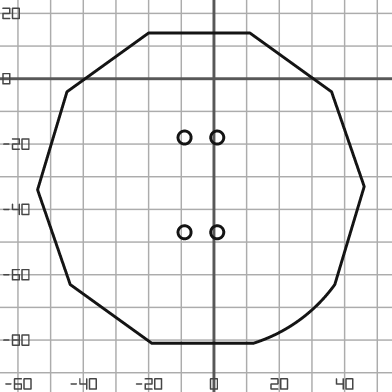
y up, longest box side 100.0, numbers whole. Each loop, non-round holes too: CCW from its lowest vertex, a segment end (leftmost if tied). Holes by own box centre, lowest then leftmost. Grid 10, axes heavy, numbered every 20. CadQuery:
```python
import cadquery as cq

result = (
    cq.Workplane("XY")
    .moveTo(-19.0, -81.0)
    .lineTo(12.0, -81.0)
    .threePointArc((26.0, -74.0), (37.0, -63.0))
    .lineTo(46.0, -33.0)
    .lineTo(36.0, -4.0)
    .lineTo(11.0, 14.0)
    .lineTo(-20.0, 14.0)
    .lineTo(-45.0, -4.0)
    .lineTo(-54.0, -34.0)
    .lineTo(-44.0, -63.0)
    .close()
    .moveTo(-9.0, -47.0)
    .circle(2.0)
    .moveTo(1.0, -47.0)
    .circle(2.0)
    .moveTo(-9.0, -18.0)
    .circle(2.0)
    .moveTo(1.0, -18.0)
    .circle(2.0)
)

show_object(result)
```